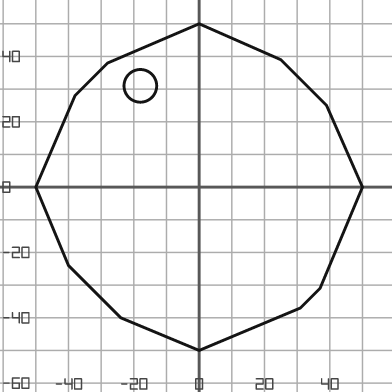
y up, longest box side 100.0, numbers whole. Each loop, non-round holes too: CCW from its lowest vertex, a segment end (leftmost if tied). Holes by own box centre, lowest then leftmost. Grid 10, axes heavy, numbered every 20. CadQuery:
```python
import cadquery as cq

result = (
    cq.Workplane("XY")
    .moveTo(0.0, -50.0)
    .lineTo(31.0, -37.0)
    .lineTo(37.0, -31.0)
    .lineTo(50.0, 0.0)
    .lineTo(39.0, 25.0)
    .lineTo(25.0, 39.0)
    .lineTo(0.0, 50.0)
    .lineTo(-28.0, 38.0)
    .lineTo(-38.0, 28.0)
    .lineTo(-50.0, 0.0)
    .lineTo(-40.0, -24.0)
    .lineTo(-24.0, -40.0)
    .close()
    .moveTo(-18.0, 31.0)
    .circle(5.0)
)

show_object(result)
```